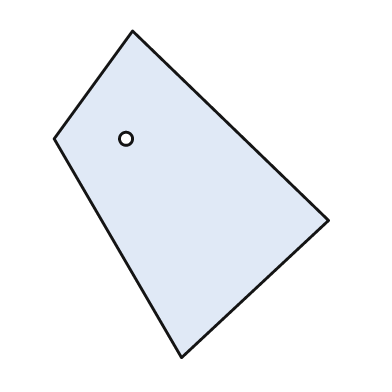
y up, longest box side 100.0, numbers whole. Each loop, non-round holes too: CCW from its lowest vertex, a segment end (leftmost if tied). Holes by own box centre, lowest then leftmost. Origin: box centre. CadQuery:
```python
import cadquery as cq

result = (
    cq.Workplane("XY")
    .moveTo(-3.0, -50.0)
    .lineTo(42.0, -8.0)
    .lineTo(-18.0, 50.0)
    .lineTo(-42.0, 17.0)
    .close()
    .moveTo(-20.0, 17.0)
    .circle(2.0)
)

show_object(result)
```